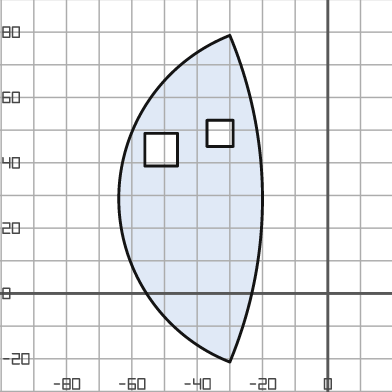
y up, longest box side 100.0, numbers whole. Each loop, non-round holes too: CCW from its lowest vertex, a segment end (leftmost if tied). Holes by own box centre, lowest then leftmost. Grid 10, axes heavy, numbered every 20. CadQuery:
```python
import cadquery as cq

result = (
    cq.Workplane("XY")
    .moveTo(-30.0, -21.0)
    .threePointArc((-20.0, 29.0), (-30.0, 79.0))
    .threePointArc((-64.0, 29.0), (-30.0, -21.0))
    .close()
    .moveTo(-56.0, 39.0)
    .lineTo(-46.0, 39.0)
    .lineTo(-46.0, 49.0)
    .lineTo(-56.0, 49.0)
    .close()
    .moveTo(-37.0, 45.0)
    .lineTo(-29.0, 45.0)
    .lineTo(-29.0, 53.0)
    .lineTo(-37.0, 53.0)
    .close()
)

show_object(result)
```